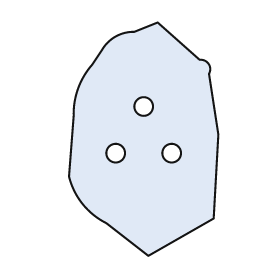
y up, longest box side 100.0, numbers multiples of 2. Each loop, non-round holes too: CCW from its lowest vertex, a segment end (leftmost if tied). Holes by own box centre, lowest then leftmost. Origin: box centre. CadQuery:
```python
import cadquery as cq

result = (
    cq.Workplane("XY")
    .moveTo(2.0, -50.0)
    .lineTo(30.0, -34.0)
    .lineTo(32.0, 2.0)
    .lineTo(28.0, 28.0)
    .threePointArc((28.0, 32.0), (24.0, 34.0))
    .lineTo(6.0, 50.0)
    .lineTo(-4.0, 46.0)
    .threePointArc((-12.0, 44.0), (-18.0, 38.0))
    .lineTo(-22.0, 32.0)
    .threePointArc((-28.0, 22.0), (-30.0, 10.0))
    .lineTo(-32.0, -16.0)
    .threePointArc((-26.0, -28.0), (-16.0, -36.0))
    .close()
    .moveTo(-12.0, -6.0)
    .circle(4.0)
    .moveTo(12.0, -6.0)
    .circle(4.0)
    .moveTo(0.0, 14.0)
    .circle(4.0)
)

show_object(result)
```